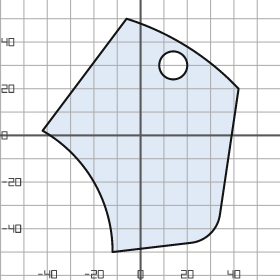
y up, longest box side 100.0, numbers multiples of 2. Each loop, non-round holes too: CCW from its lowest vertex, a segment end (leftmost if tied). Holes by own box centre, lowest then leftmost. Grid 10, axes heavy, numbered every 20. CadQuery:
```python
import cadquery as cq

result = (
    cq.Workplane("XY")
    .moveTo(-12.0, -50.0)
    .lineTo(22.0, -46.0)
    .threePointArc((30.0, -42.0), (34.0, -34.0))
    .lineTo(42.0, 20.0)
    .threePointArc((20.0, 38.0), (-6.0, 50.0))
    .lineTo(-42.0, 2.0)
    .threePointArc((-20.0, -20.0), (-12.0, -50.0))
    .close()
    .moveTo(14.0, 30.0)
    .circle(6.0)
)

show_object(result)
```